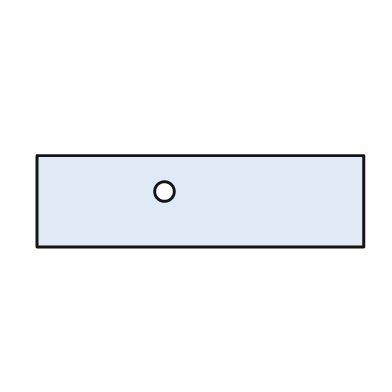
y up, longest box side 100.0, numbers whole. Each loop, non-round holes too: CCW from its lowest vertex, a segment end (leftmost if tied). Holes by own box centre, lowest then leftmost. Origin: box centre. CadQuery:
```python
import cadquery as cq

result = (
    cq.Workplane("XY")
    .moveTo(-50.0, -14.0)
    .lineTo(50.0, -14.0)
    .lineTo(50.0, 14.0)
    .lineTo(-50.0, 14.0)
    .close()
    .moveTo(-11.0, 3.0)
    .circle(3.0)
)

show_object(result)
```